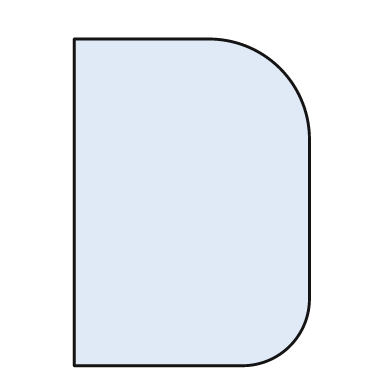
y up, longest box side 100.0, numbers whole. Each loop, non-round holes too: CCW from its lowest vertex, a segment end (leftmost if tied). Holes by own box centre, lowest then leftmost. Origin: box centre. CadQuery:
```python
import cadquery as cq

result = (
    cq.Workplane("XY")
    .moveTo(-36.0, -50.0)
    .lineTo(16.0, -50.0)
    .threePointArc((30.0, -44.0), (36.0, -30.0))
    .lineTo(36.0, 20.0)
    .threePointArc((27.0, 41.0), (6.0, 50.0))
    .lineTo(-36.0, 50.0)
    .close()
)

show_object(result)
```